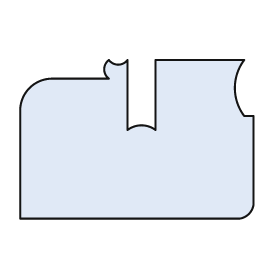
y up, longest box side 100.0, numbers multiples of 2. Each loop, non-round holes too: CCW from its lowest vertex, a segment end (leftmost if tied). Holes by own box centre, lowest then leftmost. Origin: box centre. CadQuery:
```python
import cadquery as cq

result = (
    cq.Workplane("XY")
    .moveTo(-50.0, -34.0)
    .lineTo(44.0, -34.0)
    .threePointArc((48.0, -32.0), (50.0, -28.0))
    .lineTo(50.0, 10.0)
    .lineTo(46.0, 10.0)
    .threePointArc((42.0, 22.0), (46.0, 34.0))
    .lineTo(8.0, 34.0)
    .lineTo(8.0, 4.0)
    .threePointArc((2.0, 6.0), (-4.0, 4.0))
    .lineTo(-4.0, 34.0)
    .threePointArc((-8.0, 32.0), (-12.0, 34.0))
    .threePointArc((-14.0, 30.0), (-12.0, 26.0))
    .lineTo(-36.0, 26.0)
    .threePointArc((-46.0, 22.0), (-50.0, 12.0))
    .close()
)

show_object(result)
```